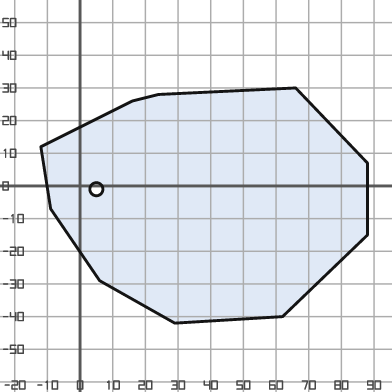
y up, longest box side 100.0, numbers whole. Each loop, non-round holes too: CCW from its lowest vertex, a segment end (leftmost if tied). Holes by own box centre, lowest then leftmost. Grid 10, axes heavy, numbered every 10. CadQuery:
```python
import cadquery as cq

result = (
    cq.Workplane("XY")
    .moveTo(29.0, -42.0)
    .lineTo(62.0, -40.0)
    .lineTo(88.0, -15.0)
    .lineTo(88.0, 7.0)
    .lineTo(66.0, 30.0)
    .lineTo(24.0, 28.0)
    .lineTo(16.0, 26.0)
    .lineTo(-12.0, 12.0)
    .lineTo(-9.0, -7.0)
    .lineTo(6.0, -29.0)
    .close()
    .moveTo(5.0, -1.0)
    .circle(2.0)
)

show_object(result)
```